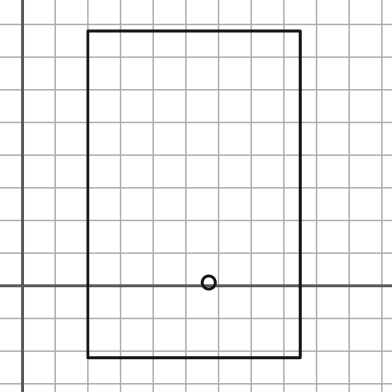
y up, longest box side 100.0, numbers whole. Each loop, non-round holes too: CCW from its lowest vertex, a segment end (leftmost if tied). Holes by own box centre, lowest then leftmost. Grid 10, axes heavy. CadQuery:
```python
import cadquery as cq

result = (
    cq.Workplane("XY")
    .moveTo(20.0, -22.0)
    .lineTo(85.0, -22.0)
    .lineTo(85.0, 78.0)
    .lineTo(20.0, 78.0)
    .close()
    .moveTo(57.0, 1.0)
    .circle(2.0)
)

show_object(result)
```